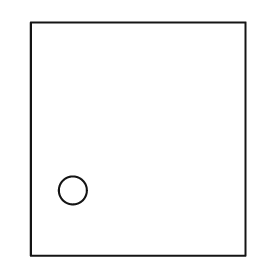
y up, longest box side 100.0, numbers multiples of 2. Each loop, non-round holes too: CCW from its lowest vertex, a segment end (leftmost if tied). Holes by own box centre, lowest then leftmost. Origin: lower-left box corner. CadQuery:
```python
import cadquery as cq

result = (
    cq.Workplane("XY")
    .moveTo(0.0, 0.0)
    .lineTo(92.0, 0.0)
    .lineTo(92.0, 100.0)
    .lineTo(0.0, 100.0)
    .close()
    .moveTo(18.0, 28.0)
    .circle(6.0)
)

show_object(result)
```